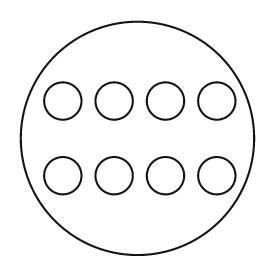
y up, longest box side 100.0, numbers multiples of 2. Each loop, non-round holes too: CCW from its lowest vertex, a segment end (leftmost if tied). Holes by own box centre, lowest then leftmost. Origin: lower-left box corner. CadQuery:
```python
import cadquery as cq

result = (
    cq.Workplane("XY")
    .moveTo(50.0, 50.0)
    .circle(50.0)
    .moveTo(18.0, 34.0)
    .circle(8.0)
    .moveTo(40.0, 34.0)
    .circle(8.0)
    .moveTo(62.0, 34.0)
    .circle(8.0)
    .moveTo(84.0, 34.0)
    .circle(8.0)
    .moveTo(18.0, 66.0)
    .circle(8.0)
    .moveTo(40.0, 66.0)
    .circle(8.0)
    .moveTo(62.0, 66.0)
    .circle(8.0)
    .moveTo(84.0, 66.0)
    .circle(8.0)
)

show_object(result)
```